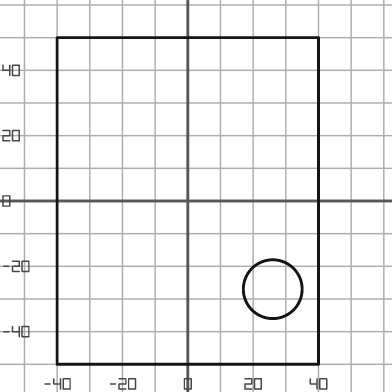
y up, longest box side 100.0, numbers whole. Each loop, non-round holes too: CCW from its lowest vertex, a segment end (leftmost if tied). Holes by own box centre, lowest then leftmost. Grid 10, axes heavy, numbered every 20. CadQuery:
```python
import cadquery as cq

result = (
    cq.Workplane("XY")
    .moveTo(-40.0, -50.0)
    .lineTo(40.0, -50.0)
    .lineTo(40.0, 50.0)
    .lineTo(-40.0, 50.0)
    .close()
    .moveTo(26.0, -27.0)
    .circle(9.0)
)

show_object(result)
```